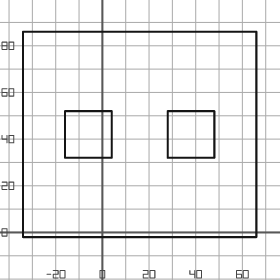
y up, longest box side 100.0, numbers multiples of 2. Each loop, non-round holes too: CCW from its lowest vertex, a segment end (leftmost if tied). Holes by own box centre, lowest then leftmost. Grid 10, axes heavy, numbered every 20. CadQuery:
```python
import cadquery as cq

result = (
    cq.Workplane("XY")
    .moveTo(-34.0, -2.0)
    .lineTo(66.0, -2.0)
    .lineTo(66.0, 86.0)
    .lineTo(-34.0, 86.0)
    .close()
    .moveTo(-16.0, 32.0)
    .lineTo(4.0, 32.0)
    .lineTo(4.0, 52.0)
    .lineTo(-16.0, 52.0)
    .close()
    .moveTo(28.0, 32.0)
    .lineTo(48.0, 32.0)
    .lineTo(48.0, 52.0)
    .lineTo(28.0, 52.0)
    .close()
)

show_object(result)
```